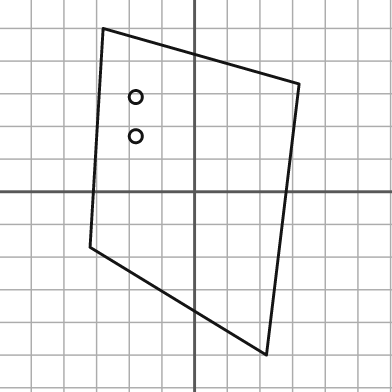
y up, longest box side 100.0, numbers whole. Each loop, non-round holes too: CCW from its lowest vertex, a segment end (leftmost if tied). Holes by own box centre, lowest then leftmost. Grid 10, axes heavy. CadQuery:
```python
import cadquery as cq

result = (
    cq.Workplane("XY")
    .moveTo(22.0, -50.0)
    .lineTo(32.0, 33.0)
    .lineTo(-28.0, 50.0)
    .lineTo(-32.0, -17.0)
    .close()
    .moveTo(-18.0, 17.0)
    .circle(2.0)
    .moveTo(-18.0, 29.0)
    .circle(2.0)
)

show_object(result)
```